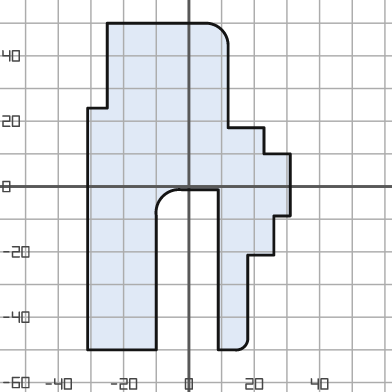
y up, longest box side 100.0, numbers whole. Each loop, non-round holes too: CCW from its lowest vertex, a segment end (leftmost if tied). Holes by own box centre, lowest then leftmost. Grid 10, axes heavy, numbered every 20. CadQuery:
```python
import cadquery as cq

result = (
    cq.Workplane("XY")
    .moveTo(-31.0, -50.0)
    .lineTo(-10.0, -50.0)
    .lineTo(-10.0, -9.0)
    .threePointArc((-8.0, -3.0), (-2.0, -1.0))
    .lineTo(9.0, -1.0)
    .lineTo(9.0, -50.0)
    .lineTo(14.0, -50.0)
    .threePointArc((17.0, -49.0), (18.0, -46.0))
    .lineTo(18.0, -21.0)
    .lineTo(26.0, -21.0)
    .lineTo(26.0, -9.0)
    .lineTo(31.0, -9.0)
    .lineTo(31.0, 10.0)
    .lineTo(23.0, 10.0)
    .lineTo(23.0, 18.0)
    .lineTo(12.0, 18.0)
    .lineTo(12.0, 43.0)
    .threePointArc((10.0, 48.0), (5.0, 50.0))
    .lineTo(-25.0, 50.0)
    .lineTo(-25.0, 24.0)
    .lineTo(-31.0, 24.0)
    .close()
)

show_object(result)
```